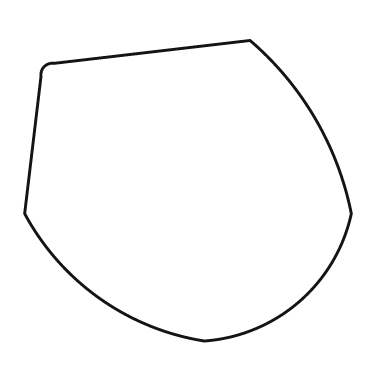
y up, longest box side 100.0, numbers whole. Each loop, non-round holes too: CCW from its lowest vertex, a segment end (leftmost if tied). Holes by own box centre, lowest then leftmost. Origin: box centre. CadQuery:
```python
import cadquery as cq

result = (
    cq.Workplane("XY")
    .moveTo(5.0, -46.0)
    .threePointArc((34.0, -34.0), (50.0, -7.0))
    .threePointArc((39.0, 22.0), (19.0, 46.0))
    .lineTo(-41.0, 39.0)
    .threePointArc((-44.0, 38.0), (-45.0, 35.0))
    .lineTo(-50.0, -7.0)
    .threePointArc((-27.0, -33.0), (5.0, -46.0))
    .close()
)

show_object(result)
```